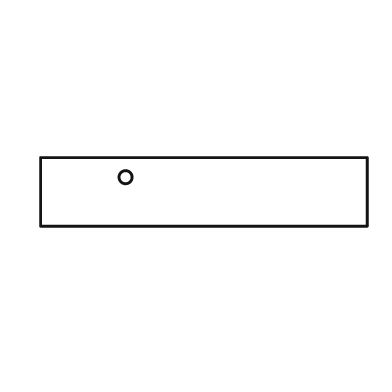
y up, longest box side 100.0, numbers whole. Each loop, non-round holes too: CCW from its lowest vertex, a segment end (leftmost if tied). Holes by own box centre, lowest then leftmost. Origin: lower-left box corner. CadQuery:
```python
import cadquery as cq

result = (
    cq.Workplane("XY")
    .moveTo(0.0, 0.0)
    .lineTo(100.0, 0.0)
    .lineTo(100.0, 21.0)
    .lineTo(0.0, 21.0)
    .close()
    .moveTo(26.0, 15.0)
    .circle(2.0)
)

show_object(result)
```